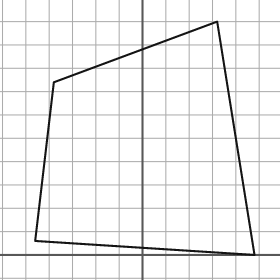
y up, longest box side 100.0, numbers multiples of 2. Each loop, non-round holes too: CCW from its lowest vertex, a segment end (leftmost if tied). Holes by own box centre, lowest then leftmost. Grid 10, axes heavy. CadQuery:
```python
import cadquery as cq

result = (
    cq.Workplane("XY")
    .moveTo(48.0, 0.0)
    .lineTo(32.0, 100.0)
    .lineTo(-38.0, 74.0)
    .lineTo(-46.0, 6.0)
    .close()
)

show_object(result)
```